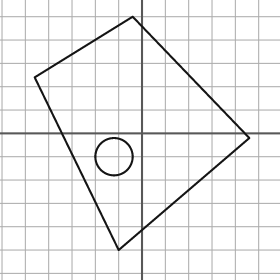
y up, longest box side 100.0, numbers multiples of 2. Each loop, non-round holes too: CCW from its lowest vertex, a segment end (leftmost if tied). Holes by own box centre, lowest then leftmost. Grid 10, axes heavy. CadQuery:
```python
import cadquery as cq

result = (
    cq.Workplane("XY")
    .moveTo(-10.0, -50.0)
    .lineTo(46.0, -2.0)
    .lineTo(-4.0, 50.0)
    .lineTo(-46.0, 24.0)
    .close()
    .moveTo(-12.0, -10.0)
    .circle(8.0)
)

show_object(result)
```